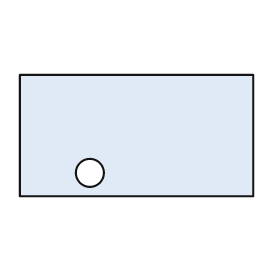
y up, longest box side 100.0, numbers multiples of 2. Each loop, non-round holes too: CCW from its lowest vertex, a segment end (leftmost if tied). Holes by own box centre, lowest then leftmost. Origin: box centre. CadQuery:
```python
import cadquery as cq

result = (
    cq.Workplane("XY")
    .moveTo(-50.0, -26.0)
    .lineTo(50.0, -26.0)
    .lineTo(50.0, 26.0)
    .lineTo(-50.0, 26.0)
    .close()
    .moveTo(-20.0, -16.0)
    .circle(6.0)
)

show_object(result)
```